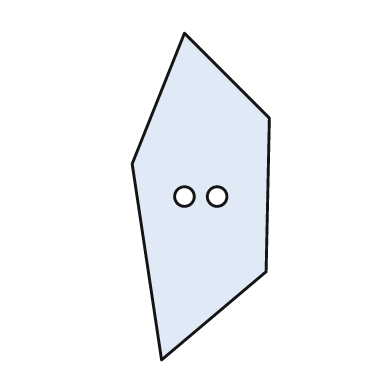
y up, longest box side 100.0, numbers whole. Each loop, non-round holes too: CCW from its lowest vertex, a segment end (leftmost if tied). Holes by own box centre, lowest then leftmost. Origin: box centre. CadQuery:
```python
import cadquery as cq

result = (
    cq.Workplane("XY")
    .moveTo(-12.0, -50.0)
    .lineTo(20.0, -23.0)
    .lineTo(21.0, 24.0)
    .lineTo(-5.0, 50.0)
    .lineTo(-21.0, 10.0)
    .close()
    .moveTo(-5.0, 0.0)
    .circle(3.0)
    .moveTo(5.0, 0.0)
    .circle(3.0)
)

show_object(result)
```